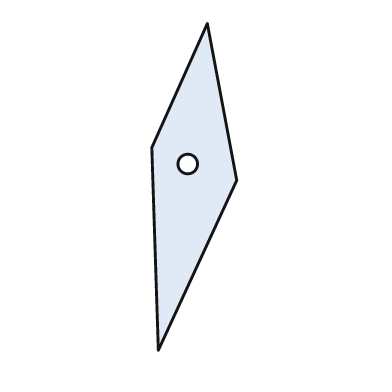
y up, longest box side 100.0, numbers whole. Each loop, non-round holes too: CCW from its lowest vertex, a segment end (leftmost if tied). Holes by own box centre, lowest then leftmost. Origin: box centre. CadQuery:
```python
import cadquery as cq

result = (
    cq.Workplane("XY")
    .moveTo(-11.0, -50.0)
    .lineTo(13.0, 2.0)
    .lineTo(4.0, 50.0)
    .lineTo(-13.0, 12.0)
    .close()
    .moveTo(-2.0, 7.0)
    .circle(3.0)
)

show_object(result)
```